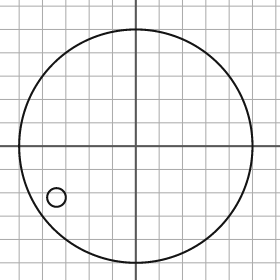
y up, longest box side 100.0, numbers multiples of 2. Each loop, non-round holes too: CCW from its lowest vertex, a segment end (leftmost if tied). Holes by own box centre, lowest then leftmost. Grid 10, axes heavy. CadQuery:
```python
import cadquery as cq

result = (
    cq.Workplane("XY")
    .moveTo(0.0, 0.0)
    .circle(50.0)
    .moveTo(-34.0, -22.0)
    .circle(4.0)
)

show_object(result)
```